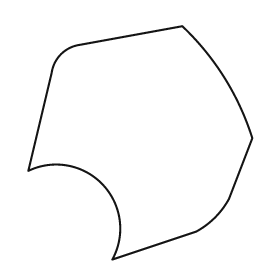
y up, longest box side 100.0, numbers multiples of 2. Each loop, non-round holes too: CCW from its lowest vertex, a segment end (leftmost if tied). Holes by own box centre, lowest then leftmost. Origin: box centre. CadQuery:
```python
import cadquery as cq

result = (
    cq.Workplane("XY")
    .moveTo(-12.0, -50.0)
    .lineTo(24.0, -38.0)
    .threePointArc((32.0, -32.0), (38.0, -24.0))
    .lineTo(48.0, 2.0)
    .threePointArc((36.0, 28.0), (18.0, 50.0))
    .lineTo(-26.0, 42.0)
    .threePointArc((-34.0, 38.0), (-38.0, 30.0))
    .lineTo(-48.0, -12.0)
    .threePointArc((-16.0, -18.0), (-12.0, -50.0))
    .close()
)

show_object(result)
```